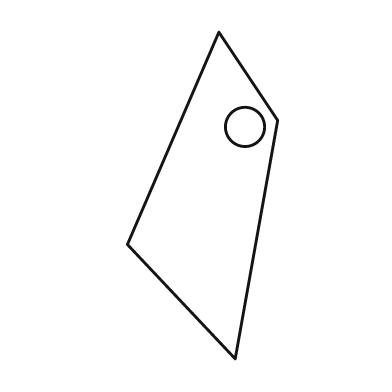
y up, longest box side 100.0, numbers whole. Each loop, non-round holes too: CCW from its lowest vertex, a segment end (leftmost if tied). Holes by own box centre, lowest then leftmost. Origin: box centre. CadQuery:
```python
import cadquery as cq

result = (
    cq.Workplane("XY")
    .moveTo(10.0, -50.0)
    .lineTo(23.0, 23.0)
    .lineTo(5.0, 50.0)
    .lineTo(-23.0, -15.0)
    .close()
    .moveTo(13.0, 21.0)
    .circle(6.0)
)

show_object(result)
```